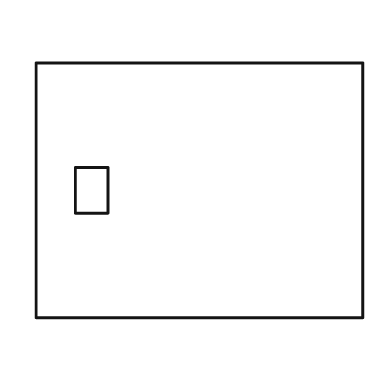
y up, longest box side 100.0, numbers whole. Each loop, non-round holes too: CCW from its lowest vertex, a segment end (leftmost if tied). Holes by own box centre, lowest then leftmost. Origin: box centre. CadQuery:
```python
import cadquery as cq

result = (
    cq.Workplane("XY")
    .moveTo(-50.0, -39.0)
    .lineTo(50.0, -39.0)
    .lineTo(50.0, 39.0)
    .lineTo(-50.0, 39.0)
    .close()
    .moveTo(-38.0, -7.0)
    .lineTo(-28.0, -7.0)
    .lineTo(-28.0, 7.0)
    .lineTo(-38.0, 7.0)
    .close()
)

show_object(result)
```